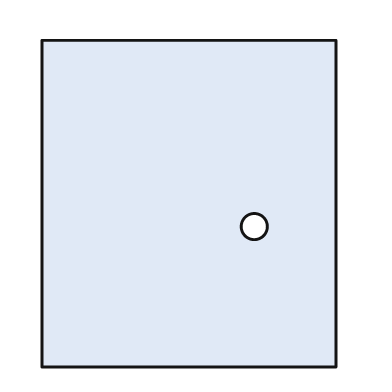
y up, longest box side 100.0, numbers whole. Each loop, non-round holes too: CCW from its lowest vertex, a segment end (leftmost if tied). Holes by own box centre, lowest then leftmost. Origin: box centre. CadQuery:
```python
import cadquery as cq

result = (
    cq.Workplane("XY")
    .moveTo(-45.0, -50.0)
    .lineTo(45.0, -50.0)
    .lineTo(45.0, 50.0)
    .lineTo(-45.0, 50.0)
    .close()
    .moveTo(20.0, -7.0)
    .circle(4.0)
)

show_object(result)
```